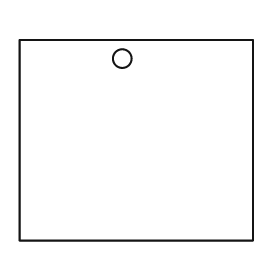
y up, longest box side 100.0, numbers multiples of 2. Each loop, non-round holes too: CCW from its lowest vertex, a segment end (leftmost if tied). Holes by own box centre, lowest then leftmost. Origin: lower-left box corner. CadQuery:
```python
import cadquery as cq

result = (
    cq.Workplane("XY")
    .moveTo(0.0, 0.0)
    .lineTo(100.0, 0.0)
    .lineTo(100.0, 86.0)
    .lineTo(0.0, 86.0)
    .close()
    .moveTo(44.0, 78.0)
    .circle(4.0)
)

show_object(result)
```